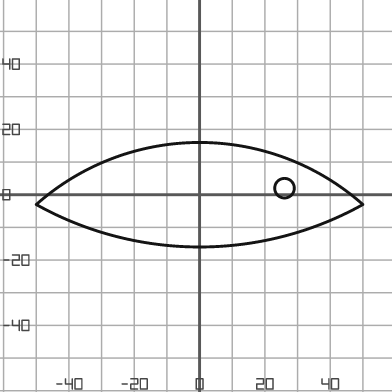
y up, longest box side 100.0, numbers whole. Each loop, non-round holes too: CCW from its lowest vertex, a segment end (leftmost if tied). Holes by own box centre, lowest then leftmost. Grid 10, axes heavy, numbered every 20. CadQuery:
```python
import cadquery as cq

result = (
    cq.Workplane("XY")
    .moveTo(-50.0, -3.0)
    .threePointArc((0.0, -16.0), (50.0, -3.0))
    .threePointArc((0.0, 16.0), (-50.0, -3.0))
    .close()
    .moveTo(26.0, 2.0)
    .circle(3.0)
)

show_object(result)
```